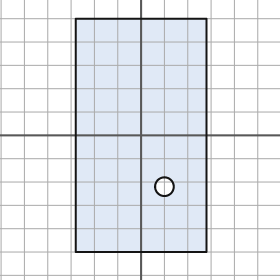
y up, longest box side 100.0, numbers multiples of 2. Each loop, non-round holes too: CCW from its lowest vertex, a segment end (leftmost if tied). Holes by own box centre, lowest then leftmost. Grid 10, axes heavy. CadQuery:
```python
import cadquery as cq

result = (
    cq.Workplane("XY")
    .moveTo(-28.0, -50.0)
    .lineTo(28.0, -50.0)
    .lineTo(28.0, 50.0)
    .lineTo(-28.0, 50.0)
    .close()
    .moveTo(10.0, -22.0)
    .circle(4.0)
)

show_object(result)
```